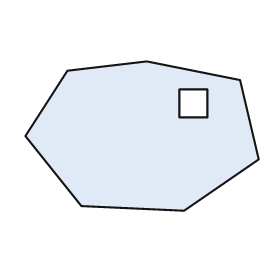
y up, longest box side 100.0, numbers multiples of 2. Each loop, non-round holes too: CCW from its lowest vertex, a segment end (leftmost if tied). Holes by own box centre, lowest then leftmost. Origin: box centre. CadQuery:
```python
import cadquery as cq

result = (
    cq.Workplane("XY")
    .moveTo(18.0, -32.0)
    .lineTo(50.0, -10.0)
    .lineTo(42.0, 24.0)
    .lineTo(2.0, 32.0)
    .lineTo(-32.0, 28.0)
    .lineTo(-50.0, 0.0)
    .lineTo(-26.0, -30.0)
    .close()
    .moveTo(16.0, 8.0)
    .lineTo(28.0, 8.0)
    .lineTo(28.0, 20.0)
    .lineTo(16.0, 20.0)
    .close()
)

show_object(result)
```